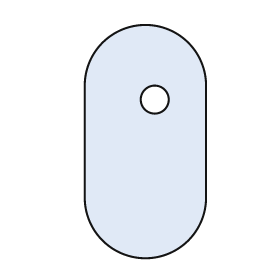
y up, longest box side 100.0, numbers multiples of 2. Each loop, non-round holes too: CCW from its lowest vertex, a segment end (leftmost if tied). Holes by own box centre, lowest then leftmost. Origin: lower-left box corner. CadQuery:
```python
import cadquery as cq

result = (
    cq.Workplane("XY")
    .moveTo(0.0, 26.0)
    .threePointArc((26.0, 0.0), (52.0, 26.0))
    .lineTo(52.0, 74.0)
    .threePointArc((26.0, 100.0), (0.0, 74.0))
    .close()
    .moveTo(30.0, 68.0)
    .circle(6.0)
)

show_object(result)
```